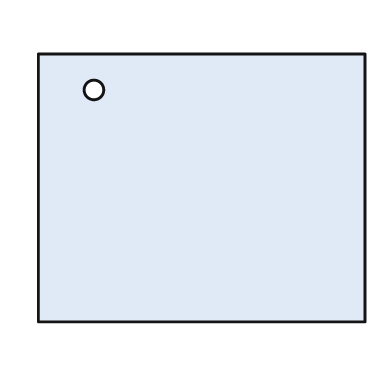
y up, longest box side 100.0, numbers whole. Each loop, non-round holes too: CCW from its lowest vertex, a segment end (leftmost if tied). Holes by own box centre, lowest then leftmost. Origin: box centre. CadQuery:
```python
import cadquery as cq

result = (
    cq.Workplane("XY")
    .moveTo(-50.0, -41.0)
    .lineTo(50.0, -41.0)
    .lineTo(50.0, 41.0)
    .lineTo(-50.0, 41.0)
    .close()
    .moveTo(-33.0, 30.0)
    .circle(3.0)
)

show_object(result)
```